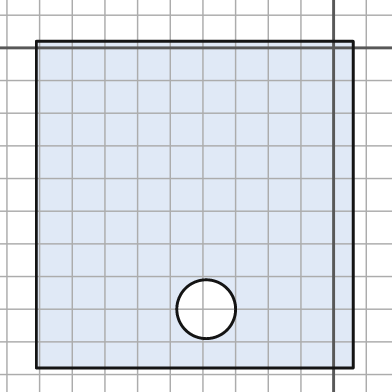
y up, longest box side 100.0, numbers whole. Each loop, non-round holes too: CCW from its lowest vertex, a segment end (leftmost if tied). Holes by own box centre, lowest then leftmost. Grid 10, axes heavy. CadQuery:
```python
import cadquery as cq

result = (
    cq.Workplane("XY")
    .moveTo(-91.0, -98.0)
    .lineTo(6.0, -98.0)
    .lineTo(6.0, 2.0)
    .lineTo(-91.0, 2.0)
    .close()
    .moveTo(-39.0, -80.0)
    .circle(9.0)
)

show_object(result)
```